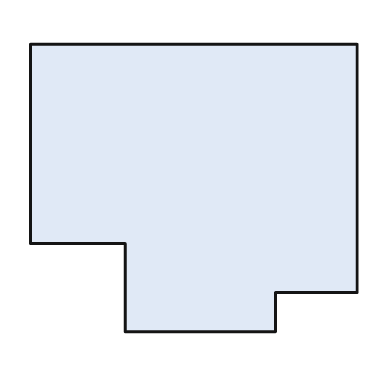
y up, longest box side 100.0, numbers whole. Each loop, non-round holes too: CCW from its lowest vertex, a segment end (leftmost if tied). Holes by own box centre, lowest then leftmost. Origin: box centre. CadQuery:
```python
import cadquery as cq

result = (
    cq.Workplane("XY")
    .moveTo(-21.0, -44.0)
    .lineTo(25.0, -44.0)
    .lineTo(25.0, -32.0)
    .lineTo(50.0, -32.0)
    .lineTo(50.0, 44.0)
    .lineTo(-50.0, 44.0)
    .lineTo(-50.0, -17.0)
    .lineTo(-21.0, -17.0)
    .close()
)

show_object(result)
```